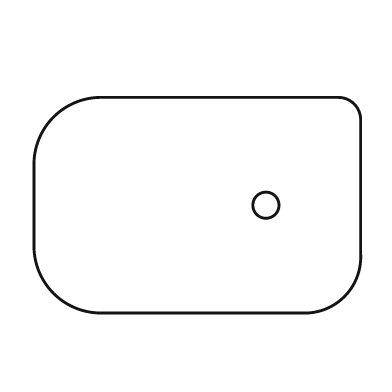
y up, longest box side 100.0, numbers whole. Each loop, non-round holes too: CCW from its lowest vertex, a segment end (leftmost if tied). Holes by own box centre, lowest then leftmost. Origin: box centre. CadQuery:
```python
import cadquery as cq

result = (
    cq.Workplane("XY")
    .moveTo(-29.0, -33.0)
    .lineTo(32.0, -33.0)
    .threePointArc((45.0, -28.0), (50.0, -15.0))
    .lineTo(50.0, 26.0)
    .threePointArc((48.0, 31.0), (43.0, 33.0))
    .lineTo(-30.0, 33.0)
    .threePointArc((-44.0, 27.0), (-50.0, 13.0))
    .lineTo(-50.0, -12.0)
    .threePointArc((-44.0, -27.0), (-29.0, -33.0))
    .close()
    .moveTo(21.0, 0.0)
    .circle(4.0)
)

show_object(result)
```